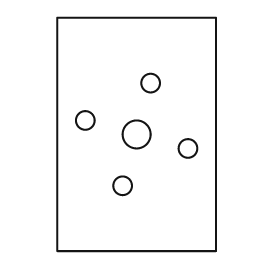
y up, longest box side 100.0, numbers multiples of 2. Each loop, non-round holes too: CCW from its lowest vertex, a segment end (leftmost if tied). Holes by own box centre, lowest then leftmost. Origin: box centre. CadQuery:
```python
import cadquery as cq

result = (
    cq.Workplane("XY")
    .moveTo(-34.0, -50.0)
    .lineTo(34.0, -50.0)
    .lineTo(34.0, 50.0)
    .lineTo(-34.0, 50.0)
    .close()
    .moveTo(-6.0, -22.0)
    .circle(4.0)
    .moveTo(22.0, -6.0)
    .circle(4.0)
    .moveTo(0.0, 0.0)
    .circle(6.0)
    .moveTo(-22.0, 6.0)
    .circle(4.0)
    .moveTo(6.0, 22.0)
    .circle(4.0)
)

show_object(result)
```